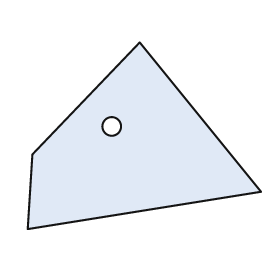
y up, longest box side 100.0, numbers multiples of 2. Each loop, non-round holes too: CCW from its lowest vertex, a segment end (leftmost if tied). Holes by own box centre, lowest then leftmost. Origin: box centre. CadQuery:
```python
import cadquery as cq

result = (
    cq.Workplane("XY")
    .moveTo(-50.0, -40.0)
    .lineTo(50.0, -24.0)
    .lineTo(-2.0, 40.0)
    .lineTo(-48.0, -8.0)
    .close()
    .moveTo(-14.0, 4.0)
    .circle(4.0)
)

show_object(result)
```